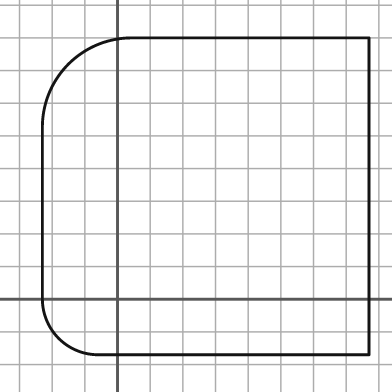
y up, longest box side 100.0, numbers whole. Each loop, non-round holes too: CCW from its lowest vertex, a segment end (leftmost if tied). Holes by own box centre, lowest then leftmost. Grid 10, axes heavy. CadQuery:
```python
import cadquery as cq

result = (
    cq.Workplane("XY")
    .moveTo(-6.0, -17.0)
    .lineTo(77.0, -17.0)
    .lineTo(77.0, 80.0)
    .lineTo(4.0, 80.0)
    .threePointArc((-15.0, 72.0), (-23.0, 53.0))
    .lineTo(-23.0, 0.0)
    .threePointArc((-18.0, -12.0), (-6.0, -17.0))
    .close()
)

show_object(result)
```